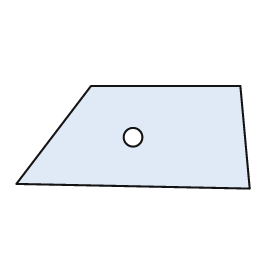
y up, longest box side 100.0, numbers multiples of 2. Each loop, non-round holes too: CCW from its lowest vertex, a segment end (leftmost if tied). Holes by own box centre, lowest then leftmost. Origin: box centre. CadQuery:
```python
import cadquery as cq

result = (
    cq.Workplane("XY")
    .moveTo(50.0, -22.0)
    .lineTo(46.0, 22.0)
    .lineTo(-18.0, 22.0)
    .lineTo(-50.0, -20.0)
    .close()
    .moveTo(0.0, 0.0)
    .circle(4.0)
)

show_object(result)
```